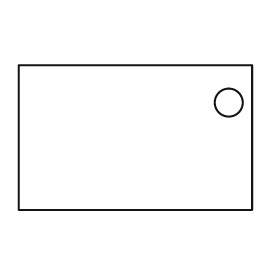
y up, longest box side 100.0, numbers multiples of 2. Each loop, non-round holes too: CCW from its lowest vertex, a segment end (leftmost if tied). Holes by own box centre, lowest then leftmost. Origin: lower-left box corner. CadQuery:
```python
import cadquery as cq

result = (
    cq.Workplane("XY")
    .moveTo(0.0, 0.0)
    .lineTo(100.0, 0.0)
    .lineTo(100.0, 62.0)
    .lineTo(0.0, 62.0)
    .close()
    .moveTo(90.0, 46.0)
    .circle(6.0)
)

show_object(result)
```